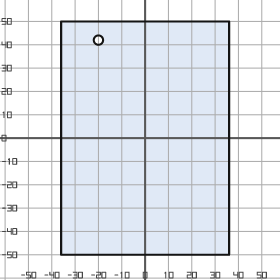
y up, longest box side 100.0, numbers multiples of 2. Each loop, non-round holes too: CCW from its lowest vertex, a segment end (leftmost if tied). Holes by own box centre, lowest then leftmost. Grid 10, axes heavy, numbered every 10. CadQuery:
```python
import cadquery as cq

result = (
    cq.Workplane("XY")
    .moveTo(-36.0, -50.0)
    .lineTo(36.0, -50.0)
    .lineTo(36.0, 50.0)
    .lineTo(-36.0, 50.0)
    .close()
    .moveTo(-20.0, 42.0)
    .circle(2.0)
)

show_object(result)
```